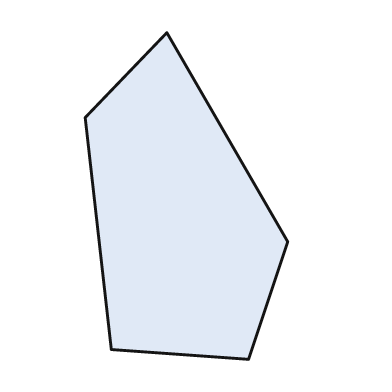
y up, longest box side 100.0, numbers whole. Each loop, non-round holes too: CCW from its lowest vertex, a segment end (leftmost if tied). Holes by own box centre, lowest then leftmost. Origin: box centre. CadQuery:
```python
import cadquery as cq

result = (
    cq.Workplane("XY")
    .moveTo(19.0, -50.0)
    .lineTo(31.0, -14.0)
    .lineTo(-6.0, 50.0)
    .lineTo(-31.0, 24.0)
    .lineTo(-23.0, -47.0)
    .close()
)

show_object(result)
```